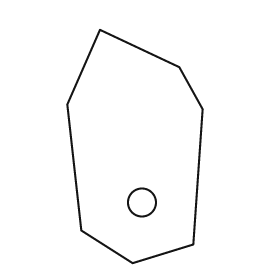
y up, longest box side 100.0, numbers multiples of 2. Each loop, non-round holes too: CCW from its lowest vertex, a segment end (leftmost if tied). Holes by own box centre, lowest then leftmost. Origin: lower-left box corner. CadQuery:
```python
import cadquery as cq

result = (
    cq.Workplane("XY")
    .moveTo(28.0, 0.0)
    .lineTo(54.0, 8.0)
    .lineTo(58.0, 66.0)
    .lineTo(48.0, 84.0)
    .lineTo(14.0, 100.0)
    .lineTo(0.0, 68.0)
    .lineTo(6.0, 14.0)
    .close()
    .moveTo(32.0, 26.0)
    .circle(6.0)
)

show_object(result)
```